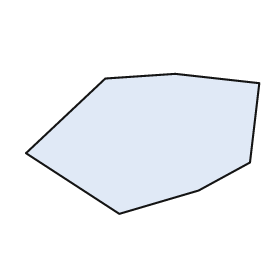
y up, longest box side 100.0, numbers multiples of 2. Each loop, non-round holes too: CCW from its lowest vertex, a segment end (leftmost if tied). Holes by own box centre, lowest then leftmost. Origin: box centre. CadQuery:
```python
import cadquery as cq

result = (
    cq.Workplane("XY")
    .moveTo(-10.0, -30.0)
    .lineTo(24.0, -20.0)
    .lineTo(46.0, -8.0)
    .lineTo(50.0, 26.0)
    .lineTo(14.0, 30.0)
    .lineTo(-16.0, 28.0)
    .lineTo(-50.0, -4.0)
    .close()
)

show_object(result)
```